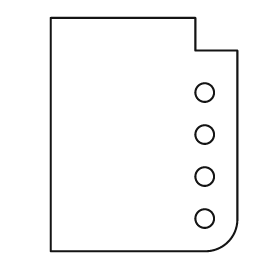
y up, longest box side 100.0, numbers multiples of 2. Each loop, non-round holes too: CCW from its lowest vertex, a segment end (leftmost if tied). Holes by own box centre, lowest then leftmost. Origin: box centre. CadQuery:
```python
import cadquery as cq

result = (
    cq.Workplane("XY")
    .moveTo(-40.0, -50.0)
    .lineTo(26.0, -50.0)
    .threePointArc((36.0, -46.0), (40.0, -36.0))
    .lineTo(40.0, 36.0)
    .lineTo(22.0, 36.0)
    .lineTo(22.0, 50.0)
    .lineTo(-40.0, 50.0)
    .close()
    .moveTo(26.0, -36.0)
    .circle(4.0)
    .moveTo(26.0, -18.0)
    .circle(4.0)
    .moveTo(26.0, 0.0)
    .circle(4.0)
    .moveTo(26.0, 18.0)
    .circle(4.0)
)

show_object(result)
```